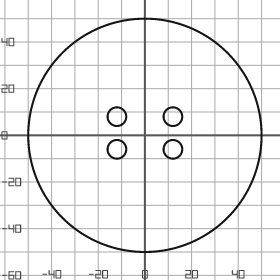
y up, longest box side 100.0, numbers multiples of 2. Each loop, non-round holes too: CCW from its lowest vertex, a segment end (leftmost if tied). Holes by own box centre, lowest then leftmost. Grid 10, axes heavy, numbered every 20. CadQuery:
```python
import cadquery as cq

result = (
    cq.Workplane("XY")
    .moveTo(0.0, 0.0)
    .circle(50.0)
    .moveTo(-12.0, -6.0)
    .circle(4.0)
    .moveTo(12.0, -6.0)
    .circle(4.0)
    .moveTo(-12.0, 8.0)
    .circle(4.0)
    .moveTo(12.0, 8.0)
    .circle(4.0)
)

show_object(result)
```